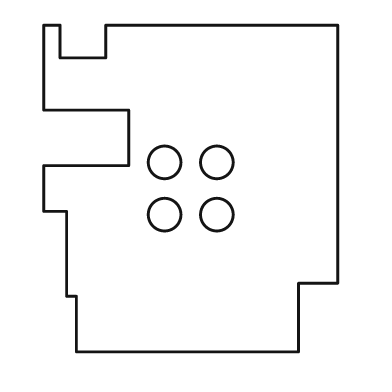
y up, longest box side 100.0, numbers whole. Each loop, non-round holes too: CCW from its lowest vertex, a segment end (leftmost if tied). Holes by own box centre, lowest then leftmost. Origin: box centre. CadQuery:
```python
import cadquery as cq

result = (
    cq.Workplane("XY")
    .moveTo(-35.0, -50.0)
    .lineTo(33.0, -50.0)
    .lineTo(33.0, -29.0)
    .lineTo(45.0, -29.0)
    .lineTo(45.0, 50.0)
    .lineTo(-26.0, 50.0)
    .lineTo(-26.0, 40.0)
    .lineTo(-40.0, 40.0)
    .lineTo(-40.0, 50.0)
    .lineTo(-45.0, 50.0)
    .lineTo(-45.0, 24.0)
    .lineTo(-19.0, 24.0)
    .lineTo(-19.0, 7.0)
    .lineTo(-45.0, 7.0)
    .lineTo(-45.0, -7.0)
    .lineTo(-38.0, -7.0)
    .lineTo(-38.0, -33.0)
    .lineTo(-35.0, -33.0)
    .close()
    .moveTo(-8.0, -8.0)
    .circle(5.0)
    .moveTo(8.0, -8.0)
    .circle(5.0)
    .moveTo(-8.0, 8.0)
    .circle(5.0)
    .moveTo(8.0, 8.0)
    .circle(5.0)
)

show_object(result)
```